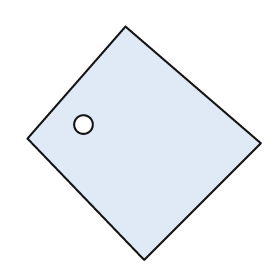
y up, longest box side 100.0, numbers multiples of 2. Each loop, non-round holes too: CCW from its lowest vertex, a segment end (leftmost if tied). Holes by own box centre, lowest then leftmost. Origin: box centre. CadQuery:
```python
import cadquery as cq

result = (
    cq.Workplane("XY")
    .moveTo(0.0, -50.0)
    .lineTo(50.0, 0.0)
    .lineTo(-8.0, 50.0)
    .lineTo(-50.0, 2.0)
    .close()
    .moveTo(-26.0, 8.0)
    .circle(4.0)
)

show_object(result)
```